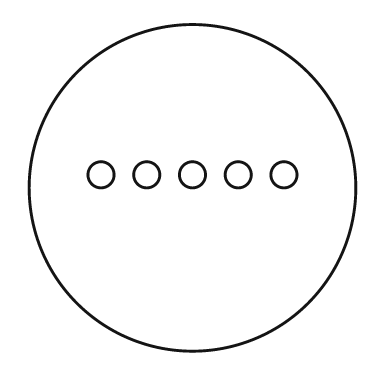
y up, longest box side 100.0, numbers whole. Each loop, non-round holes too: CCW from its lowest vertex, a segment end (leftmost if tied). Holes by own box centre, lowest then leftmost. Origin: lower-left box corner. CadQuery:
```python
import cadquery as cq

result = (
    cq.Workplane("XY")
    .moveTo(50.0, 50.0)
    .circle(50.0)
    .moveTo(22.0, 54.0)
    .circle(4.0)
    .moveTo(36.0, 54.0)
    .circle(4.0)
    .moveTo(50.0, 54.0)
    .circle(4.0)
    .moveTo(64.0, 54.0)
    .circle(4.0)
    .moveTo(78.0, 54.0)
    .circle(4.0)
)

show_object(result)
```